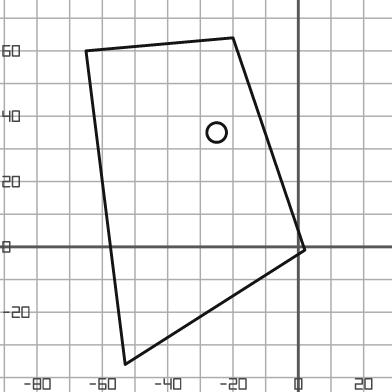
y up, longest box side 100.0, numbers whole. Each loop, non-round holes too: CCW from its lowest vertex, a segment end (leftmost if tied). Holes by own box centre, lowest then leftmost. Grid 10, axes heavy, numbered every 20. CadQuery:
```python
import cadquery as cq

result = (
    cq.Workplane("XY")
    .moveTo(-53.0, -36.0)
    .lineTo(2.0, -1.0)
    .lineTo(-20.0, 64.0)
    .lineTo(-65.0, 60.0)
    .close()
    .moveTo(-25.0, 35.0)
    .circle(3.0)
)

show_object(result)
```